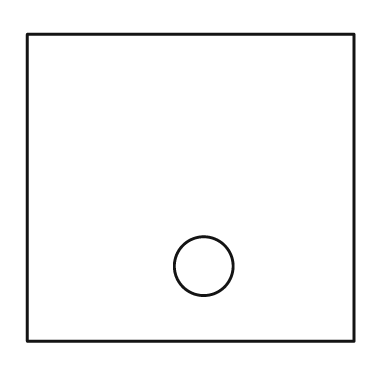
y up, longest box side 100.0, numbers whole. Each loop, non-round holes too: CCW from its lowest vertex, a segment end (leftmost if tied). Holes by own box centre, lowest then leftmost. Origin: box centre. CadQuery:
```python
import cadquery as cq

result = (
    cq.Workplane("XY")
    .moveTo(-50.0, -47.0)
    .lineTo(50.0, -47.0)
    .lineTo(50.0, 47.0)
    .lineTo(-50.0, 47.0)
    .close()
    .moveTo(4.0, -24.0)
    .circle(9.0)
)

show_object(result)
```